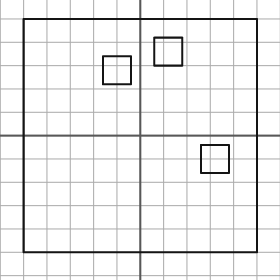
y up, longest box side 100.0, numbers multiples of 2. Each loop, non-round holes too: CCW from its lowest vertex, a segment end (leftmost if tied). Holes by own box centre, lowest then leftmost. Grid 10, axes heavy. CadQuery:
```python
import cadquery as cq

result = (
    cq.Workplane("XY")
    .moveTo(-50.0, -50.0)
    .lineTo(50.0, -50.0)
    .lineTo(50.0, 50.0)
    .lineTo(-50.0, 50.0)
    .close()
    .moveTo(26.0, -16.0)
    .lineTo(38.0, -16.0)
    .lineTo(38.0, -4.0)
    .lineTo(26.0, -4.0)
    .close()
    .moveTo(-16.0, 22.0)
    .lineTo(-4.0, 22.0)
    .lineTo(-4.0, 34.0)
    .lineTo(-16.0, 34.0)
    .close()
    .moveTo(6.0, 30.0)
    .lineTo(18.0, 30.0)
    .lineTo(18.0, 42.0)
    .lineTo(6.0, 42.0)
    .close()
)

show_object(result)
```